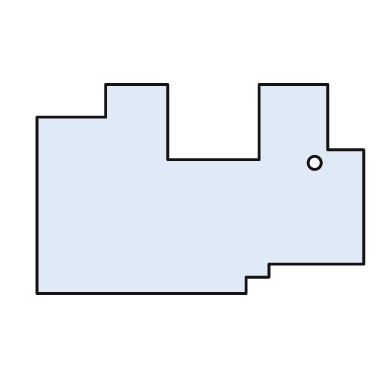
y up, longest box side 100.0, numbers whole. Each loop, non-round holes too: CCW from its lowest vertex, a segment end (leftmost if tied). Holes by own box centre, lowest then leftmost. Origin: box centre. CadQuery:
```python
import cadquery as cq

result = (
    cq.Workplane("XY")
    .moveTo(-50.0, -32.0)
    .lineTo(14.0, -32.0)
    .lineTo(14.0, -27.0)
    .lineTo(21.0, -27.0)
    .lineTo(21.0, -23.0)
    .lineTo(50.0, -23.0)
    .lineTo(50.0, 12.0)
    .lineTo(39.0, 12.0)
    .lineTo(39.0, 32.0)
    .lineTo(18.0, 32.0)
    .lineTo(18.0, 9.0)
    .lineTo(-10.0, 9.0)
    .lineTo(-10.0, 32.0)
    .lineTo(-29.0, 32.0)
    .lineTo(-29.0, 22.0)
    .lineTo(-50.0, 22.0)
    .close()
    .moveTo(35.0, 8.0)
    .circle(2.0)
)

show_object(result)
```